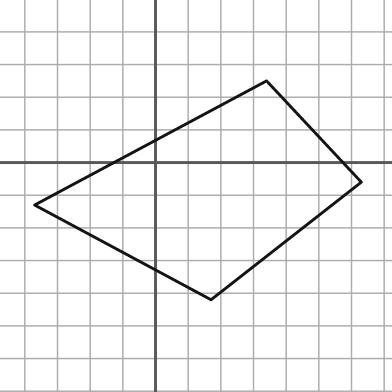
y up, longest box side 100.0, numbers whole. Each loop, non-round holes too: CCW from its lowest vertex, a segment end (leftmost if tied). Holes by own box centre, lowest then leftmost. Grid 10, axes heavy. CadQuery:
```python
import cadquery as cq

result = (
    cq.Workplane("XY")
    .moveTo(17.0, -42.0)
    .lineTo(63.0, -6.0)
    .lineTo(34.0, 25.0)
    .lineTo(-37.0, -13.0)
    .close()
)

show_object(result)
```